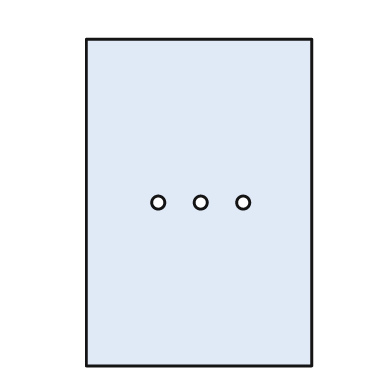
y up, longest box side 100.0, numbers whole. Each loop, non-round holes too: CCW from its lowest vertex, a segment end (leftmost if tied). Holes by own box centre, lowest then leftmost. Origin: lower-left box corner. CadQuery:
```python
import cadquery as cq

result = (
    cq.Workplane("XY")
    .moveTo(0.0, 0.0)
    .lineTo(69.0, 0.0)
    .lineTo(69.0, 100.0)
    .lineTo(0.0, 100.0)
    .close()
    .moveTo(22.0, 50.0)
    .circle(2.0)
    .moveTo(35.0, 50.0)
    .circle(2.0)
    .moveTo(48.0, 50.0)
    .circle(2.0)
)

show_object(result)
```